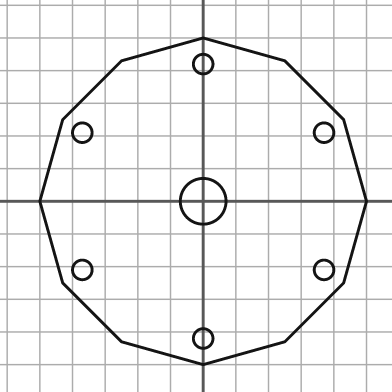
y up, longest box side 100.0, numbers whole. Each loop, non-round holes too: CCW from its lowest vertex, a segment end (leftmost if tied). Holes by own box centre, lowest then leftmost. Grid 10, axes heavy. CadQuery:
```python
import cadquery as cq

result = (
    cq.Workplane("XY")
    .moveTo(0.0, -50.0)
    .lineTo(25.0, -43.0)
    .lineTo(43.0, -25.0)
    .lineTo(50.0, 0.0)
    .lineTo(43.0, 25.0)
    .lineTo(25.0, 43.0)
    .lineTo(0.0, 50.0)
    .lineTo(-25.0, 43.0)
    .lineTo(-43.0, 25.0)
    .lineTo(-50.0, 0.0)
    .lineTo(-43.0, -25.0)
    .lineTo(-25.0, -43.0)
    .close()
    .moveTo(0.0, -42.0)
    .circle(3.0)
    .moveTo(-37.0, -21.0)
    .circle(3.0)
    .moveTo(37.0, -21.0)
    .circle(3.0)
    .moveTo(0.0, 0.0)
    .circle(7.0)
    .moveTo(-37.0, 21.0)
    .circle(3.0)
    .moveTo(37.0, 21.0)
    .circle(3.0)
    .moveTo(0.0, 42.0)
    .circle(3.0)
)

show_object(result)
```